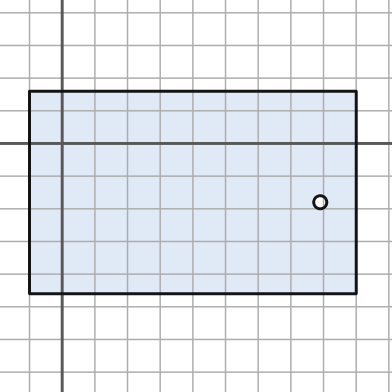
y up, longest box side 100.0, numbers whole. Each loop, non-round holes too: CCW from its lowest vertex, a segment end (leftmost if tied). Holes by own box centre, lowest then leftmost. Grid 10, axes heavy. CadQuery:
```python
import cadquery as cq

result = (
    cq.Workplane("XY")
    .moveTo(-10.0, -46.0)
    .lineTo(90.0, -46.0)
    .lineTo(90.0, 16.0)
    .lineTo(-10.0, 16.0)
    .close()
    .moveTo(79.0, -18.0)
    .circle(2.0)
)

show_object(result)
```